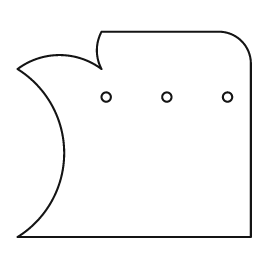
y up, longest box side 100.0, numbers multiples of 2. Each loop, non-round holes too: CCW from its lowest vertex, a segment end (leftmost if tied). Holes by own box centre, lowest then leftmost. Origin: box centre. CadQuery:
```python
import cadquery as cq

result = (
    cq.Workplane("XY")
    .moveTo(-50.0, -44.0)
    .lineTo(50.0, -44.0)
    .lineTo(50.0, 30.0)
    .threePointArc((46.0, 40.0), (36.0, 44.0))
    .lineTo(-14.0, 44.0)
    .threePointArc((-16.0, 36.0), (-14.0, 28.0))
    .threePointArc((-32.0, 34.0), (-50.0, 28.0))
    .threePointArc((-30.0, -8.0), (-50.0, -44.0))
    .close()
    .moveTo(-12.0, 16.0)
    .circle(2.0)
    .moveTo(14.0, 16.0)
    .circle(2.0)
    .moveTo(40.0, 16.0)
    .circle(2.0)
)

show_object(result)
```